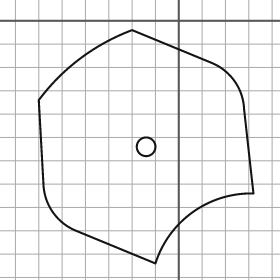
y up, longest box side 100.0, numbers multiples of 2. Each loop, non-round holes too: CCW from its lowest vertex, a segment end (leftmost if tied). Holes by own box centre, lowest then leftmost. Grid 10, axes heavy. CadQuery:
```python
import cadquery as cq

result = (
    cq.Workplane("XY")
    .moveTo(-10.0, -104.0)
    .threePointArc((6.0, -82.0), (32.0, -74.0))
    .lineTo(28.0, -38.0)
    .threePointArc((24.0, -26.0), (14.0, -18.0))
    .lineTo(-20.0, -4.0)
    .threePointArc((-42.0, -16.0), (-60.0, -34.0))
    .lineTo(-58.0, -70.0)
    .threePointArc((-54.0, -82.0), (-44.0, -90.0))
    .close()
    .moveTo(-14.0, -54.0)
    .circle(4.0)
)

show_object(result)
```